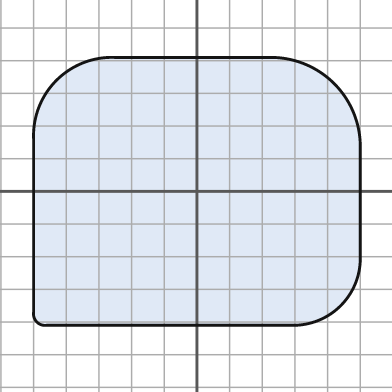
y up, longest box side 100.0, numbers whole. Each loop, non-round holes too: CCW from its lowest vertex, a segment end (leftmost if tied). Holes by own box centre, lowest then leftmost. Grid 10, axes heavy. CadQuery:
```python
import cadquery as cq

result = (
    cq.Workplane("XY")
    .moveTo(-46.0, -41.0)
    .lineTo(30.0, -41.0)
    .threePointArc((44.0, -35.0), (50.0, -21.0))
    .lineTo(50.0, 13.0)
    .threePointArc((42.0, 33.0), (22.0, 41.0))
    .lineTo(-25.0, 41.0)
    .threePointArc((-43.0, 34.0), (-50.0, 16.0))
    .lineTo(-50.0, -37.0)
    .threePointArc((-49.0, -40.0), (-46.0, -41.0))
    .close()
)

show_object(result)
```